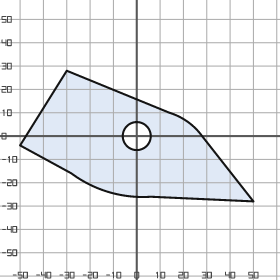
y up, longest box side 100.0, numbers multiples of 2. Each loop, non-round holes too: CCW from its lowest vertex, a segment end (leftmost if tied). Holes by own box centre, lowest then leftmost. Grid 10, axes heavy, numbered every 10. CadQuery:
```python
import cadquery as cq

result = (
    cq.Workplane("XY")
    .moveTo(50.0, -28.0)
    .lineTo(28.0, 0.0)
    .threePointArc((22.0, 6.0), (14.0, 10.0))
    .lineTo(-30.0, 28.0)
    .lineTo(-50.0, -4.0)
    .lineTo(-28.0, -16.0)
    .threePointArc((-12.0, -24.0), (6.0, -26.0))
    .close()
    .moveTo(0.0, 0.0)
    .circle(6.0)
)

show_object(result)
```